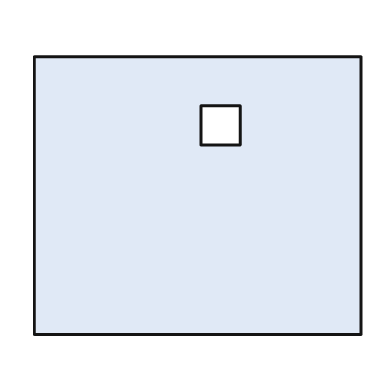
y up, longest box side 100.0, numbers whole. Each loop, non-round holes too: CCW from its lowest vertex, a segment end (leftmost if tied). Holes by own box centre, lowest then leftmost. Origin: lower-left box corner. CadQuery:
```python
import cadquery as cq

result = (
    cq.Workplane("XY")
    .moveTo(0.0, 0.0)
    .lineTo(100.0, 0.0)
    .lineTo(100.0, 85.0)
    .lineTo(0.0, 85.0)
    .close()
    .moveTo(51.0, 58.0)
    .lineTo(63.0, 58.0)
    .lineTo(63.0, 70.0)
    .lineTo(51.0, 70.0)
    .close()
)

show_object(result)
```